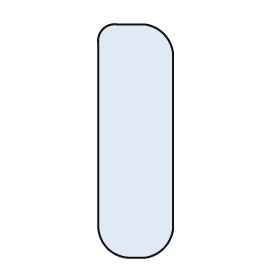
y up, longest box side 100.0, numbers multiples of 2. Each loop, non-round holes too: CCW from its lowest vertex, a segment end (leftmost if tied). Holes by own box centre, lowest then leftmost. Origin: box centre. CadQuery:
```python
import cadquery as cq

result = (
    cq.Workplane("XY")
    .moveTo(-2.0, -50.0)
    .lineTo(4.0, -50.0)
    .threePointArc((12.0, -46.0), (16.0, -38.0))
    .lineTo(16.0, 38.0)
    .threePointArc((12.0, 46.0), (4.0, 50.0))
    .lineTo(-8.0, 50.0)
    .threePointArc((-14.0, 48.0), (-16.0, 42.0))
    .lineTo(-16.0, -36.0)
    .threePointArc((-12.0, -46.0), (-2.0, -50.0))
    .close()
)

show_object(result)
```